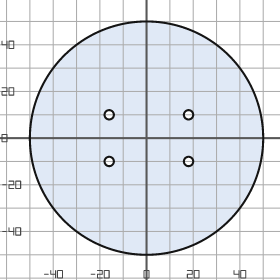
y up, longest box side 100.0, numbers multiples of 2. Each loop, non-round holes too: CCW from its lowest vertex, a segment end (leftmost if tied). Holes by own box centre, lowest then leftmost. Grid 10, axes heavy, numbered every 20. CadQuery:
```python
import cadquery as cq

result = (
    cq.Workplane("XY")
    .moveTo(0.0, 0.0)
    .circle(50.0)
    .moveTo(-16.0, -10.0)
    .circle(2.0)
    .moveTo(18.0, -10.0)
    .circle(2.0)
    .moveTo(-16.0, 10.0)
    .circle(2.0)
    .moveTo(18.0, 10.0)
    .circle(2.0)
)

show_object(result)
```